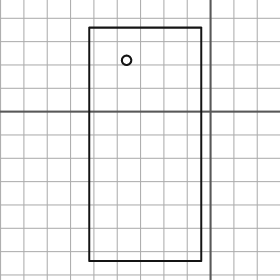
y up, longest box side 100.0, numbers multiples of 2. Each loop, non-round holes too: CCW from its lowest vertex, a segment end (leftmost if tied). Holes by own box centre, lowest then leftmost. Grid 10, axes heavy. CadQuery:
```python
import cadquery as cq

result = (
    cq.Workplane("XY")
    .moveTo(-52.0, -64.0)
    .lineTo(-4.0, -64.0)
    .lineTo(-4.0, 36.0)
    .lineTo(-52.0, 36.0)
    .close()
    .moveTo(-36.0, 22.0)
    .circle(2.0)
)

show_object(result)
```